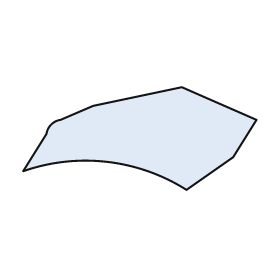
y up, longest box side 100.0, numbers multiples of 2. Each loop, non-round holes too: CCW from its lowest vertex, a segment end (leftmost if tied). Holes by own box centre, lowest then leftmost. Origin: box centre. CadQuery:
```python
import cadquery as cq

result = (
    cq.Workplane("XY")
    .moveTo(20.0, -22.0)
    .lineTo(40.0, -8.0)
    .lineTo(50.0, 8.0)
    .lineTo(18.0, 22.0)
    .lineTo(-20.0, 14.0)
    .lineTo(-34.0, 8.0)
    .threePointArc((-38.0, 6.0), (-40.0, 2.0))
    .lineTo(-50.0, -14.0)
    .threePointArc((-14.0, -10.0), (20.0, -22.0))
    .close()
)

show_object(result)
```